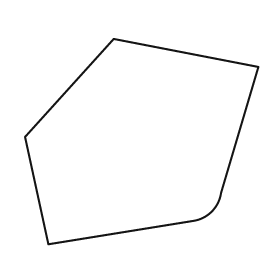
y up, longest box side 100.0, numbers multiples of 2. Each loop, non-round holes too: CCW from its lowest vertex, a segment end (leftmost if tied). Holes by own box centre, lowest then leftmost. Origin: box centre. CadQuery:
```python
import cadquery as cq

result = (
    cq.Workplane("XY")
    .moveTo(-40.0, -44.0)
    .lineTo(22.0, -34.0)
    .threePointArc((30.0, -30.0), (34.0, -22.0))
    .lineTo(50.0, 32.0)
    .lineTo(-12.0, 44.0)
    .lineTo(-50.0, 2.0)
    .close()
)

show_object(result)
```